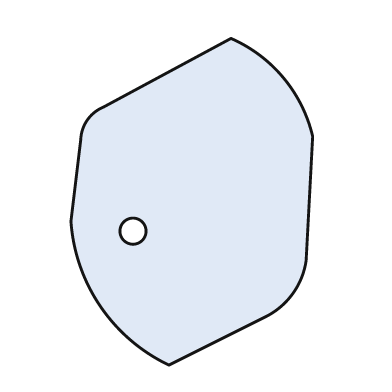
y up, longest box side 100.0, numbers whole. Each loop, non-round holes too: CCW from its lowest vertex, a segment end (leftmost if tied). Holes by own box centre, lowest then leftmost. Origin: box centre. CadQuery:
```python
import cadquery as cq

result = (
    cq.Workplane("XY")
    .moveTo(-7.0, -50.0)
    .lineTo(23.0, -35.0)
    .threePointArc((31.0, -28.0), (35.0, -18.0))
    .lineTo(37.0, 20.0)
    .threePointArc((28.0, 38.0), (12.0, 50.0))
    .lineTo(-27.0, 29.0)
    .threePointArc((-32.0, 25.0), (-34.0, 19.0))
    .lineTo(-37.0, -6.0)
    .threePointArc((-28.0, -32.0), (-7.0, -50.0))
    .close()
    .moveTo(-18.0, -9.0)
    .circle(4.0)
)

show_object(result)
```